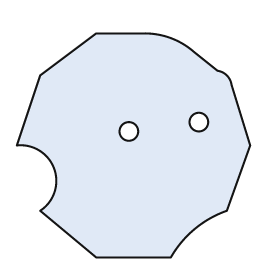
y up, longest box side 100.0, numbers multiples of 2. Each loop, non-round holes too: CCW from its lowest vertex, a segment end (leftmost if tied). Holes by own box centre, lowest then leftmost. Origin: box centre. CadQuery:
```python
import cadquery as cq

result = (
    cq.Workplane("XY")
    .moveTo(-16.0, -48.0)
    .lineTo(16.0, -48.0)
    .threePointArc((26.0, -36.0), (40.0, -28.0))
    .lineTo(50.0, 0.0)
    .lineTo(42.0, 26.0)
    .threePointArc((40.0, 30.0), (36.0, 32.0))
    .lineTo(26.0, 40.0)
    .threePointArc((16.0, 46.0), (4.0, 48.0))
    .lineTo(-16.0, 48.0)
    .lineTo(-40.0, 30.0)
    .lineTo(-50.0, 0.0)
    .threePointArc((-34.0, -10.0), (-40.0, -28.0))
    .close()
    .moveTo(-2.0, 6.0)
    .circle(4.0)
    .moveTo(28.0, 10.0)
    .circle(4.0)
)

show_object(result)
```